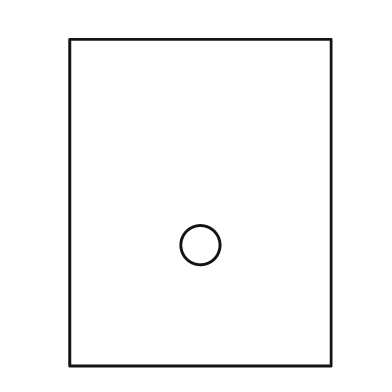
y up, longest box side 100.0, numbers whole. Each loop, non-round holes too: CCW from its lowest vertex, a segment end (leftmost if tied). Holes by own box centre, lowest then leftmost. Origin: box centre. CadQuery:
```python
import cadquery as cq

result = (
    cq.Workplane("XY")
    .moveTo(-40.0, -50.0)
    .lineTo(40.0, -50.0)
    .lineTo(40.0, 50.0)
    .lineTo(-40.0, 50.0)
    .close()
    .moveTo(0.0, -13.0)
    .circle(6.0)
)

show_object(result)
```